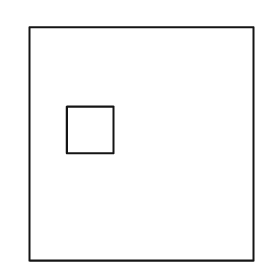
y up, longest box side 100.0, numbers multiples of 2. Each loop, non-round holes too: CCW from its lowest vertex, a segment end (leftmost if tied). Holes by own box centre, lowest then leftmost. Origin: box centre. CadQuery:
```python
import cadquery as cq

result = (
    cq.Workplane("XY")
    .moveTo(-48.0, -50.0)
    .lineTo(48.0, -50.0)
    .lineTo(48.0, 50.0)
    .lineTo(-48.0, 50.0)
    .close()
    .moveTo(-32.0, -4.0)
    .lineTo(-12.0, -4.0)
    .lineTo(-12.0, 16.0)
    .lineTo(-32.0, 16.0)
    .close()
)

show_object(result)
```